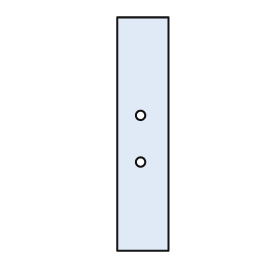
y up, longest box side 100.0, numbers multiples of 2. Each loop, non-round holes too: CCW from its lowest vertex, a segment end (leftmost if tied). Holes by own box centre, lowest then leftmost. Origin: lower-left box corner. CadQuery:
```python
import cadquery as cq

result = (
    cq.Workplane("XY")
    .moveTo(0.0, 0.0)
    .lineTo(22.0, 0.0)
    .lineTo(22.0, 100.0)
    .lineTo(0.0, 100.0)
    .close()
    .moveTo(10.0, 38.0)
    .circle(2.0)
    .moveTo(10.0, 58.0)
    .circle(2.0)
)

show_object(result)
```